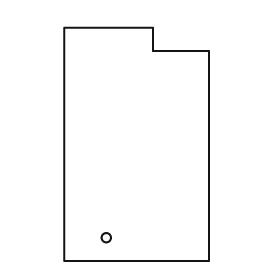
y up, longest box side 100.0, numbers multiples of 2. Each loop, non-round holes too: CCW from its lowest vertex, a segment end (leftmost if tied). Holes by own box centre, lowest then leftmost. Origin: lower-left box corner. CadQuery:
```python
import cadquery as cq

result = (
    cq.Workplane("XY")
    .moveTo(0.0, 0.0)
    .lineTo(62.0, 0.0)
    .lineTo(62.0, 90.0)
    .lineTo(38.0, 90.0)
    .lineTo(38.0, 100.0)
    .lineTo(0.0, 100.0)
    .close()
    .moveTo(18.0, 10.0)
    .circle(2.0)
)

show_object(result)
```